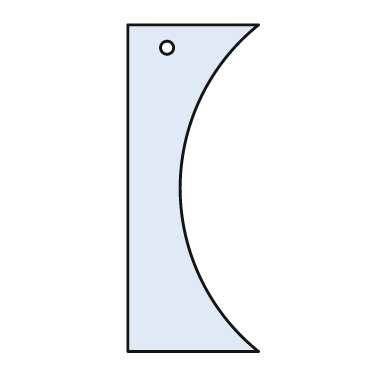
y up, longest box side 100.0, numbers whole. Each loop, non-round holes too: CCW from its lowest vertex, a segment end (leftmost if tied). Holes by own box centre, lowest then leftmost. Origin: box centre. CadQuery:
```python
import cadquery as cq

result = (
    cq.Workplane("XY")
    .moveTo(-20.0, -50.0)
    .lineTo(20.0, -50.0)
    .threePointArc((-4.0, 0.0), (20.0, 50.0))
    .lineTo(-20.0, 50.0)
    .close()
    .moveTo(-8.0, 43.0)
    .circle(2.0)
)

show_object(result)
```